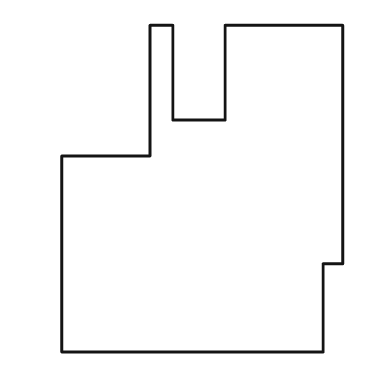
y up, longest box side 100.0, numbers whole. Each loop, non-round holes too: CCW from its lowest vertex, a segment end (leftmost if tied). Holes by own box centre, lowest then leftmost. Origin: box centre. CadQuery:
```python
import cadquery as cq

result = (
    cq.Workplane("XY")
    .moveTo(-43.0, -50.0)
    .lineTo(37.0, -50.0)
    .lineTo(37.0, -23.0)
    .lineTo(43.0, -23.0)
    .lineTo(43.0, 50.0)
    .lineTo(7.0, 50.0)
    .lineTo(7.0, 21.0)
    .lineTo(-9.0, 21.0)
    .lineTo(-9.0, 50.0)
    .lineTo(-16.0, 50.0)
    .lineTo(-16.0, 10.0)
    .lineTo(-43.0, 10.0)
    .close()
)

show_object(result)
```